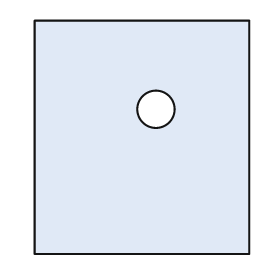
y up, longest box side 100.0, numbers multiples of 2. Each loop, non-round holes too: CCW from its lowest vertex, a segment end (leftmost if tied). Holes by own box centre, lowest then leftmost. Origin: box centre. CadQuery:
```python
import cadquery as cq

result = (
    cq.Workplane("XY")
    .moveTo(-46.0, -50.0)
    .lineTo(46.0, -50.0)
    .lineTo(46.0, 50.0)
    .lineTo(-46.0, 50.0)
    .close()
    .moveTo(6.0, 12.0)
    .circle(8.0)
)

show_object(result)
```